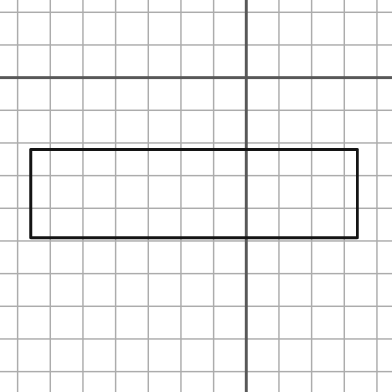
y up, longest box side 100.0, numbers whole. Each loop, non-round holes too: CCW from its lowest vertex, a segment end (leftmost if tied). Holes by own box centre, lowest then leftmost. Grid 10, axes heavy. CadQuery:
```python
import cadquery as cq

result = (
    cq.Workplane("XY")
    .moveTo(-66.0, -49.0)
    .lineTo(34.0, -49.0)
    .lineTo(34.0, -22.0)
    .lineTo(-66.0, -22.0)
    .close()
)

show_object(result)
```